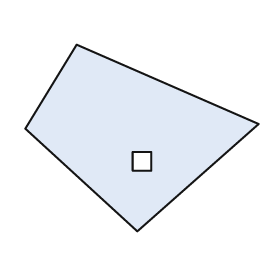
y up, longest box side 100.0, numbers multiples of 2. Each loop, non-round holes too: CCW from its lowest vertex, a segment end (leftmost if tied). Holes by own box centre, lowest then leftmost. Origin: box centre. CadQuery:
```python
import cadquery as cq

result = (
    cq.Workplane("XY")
    .moveTo(-2.0, -40.0)
    .lineTo(50.0, 6.0)
    .lineTo(-28.0, 40.0)
    .lineTo(-50.0, 4.0)
    .close()
    .moveTo(-4.0, -14.0)
    .lineTo(4.0, -14.0)
    .lineTo(4.0, -6.0)
    .lineTo(-4.0, -6.0)
    .close()
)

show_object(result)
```